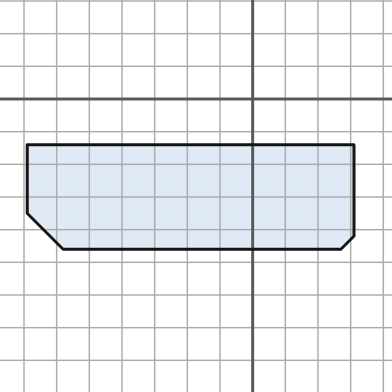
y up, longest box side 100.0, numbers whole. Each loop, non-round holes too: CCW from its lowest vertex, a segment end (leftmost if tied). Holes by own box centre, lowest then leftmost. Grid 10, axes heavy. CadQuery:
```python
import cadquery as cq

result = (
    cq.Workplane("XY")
    .moveTo(-58.0, -46.0)
    .lineTo(27.0, -46.0)
    .lineTo(31.0, -42.0)
    .lineTo(31.0, -14.0)
    .lineTo(-69.0, -14.0)
    .lineTo(-69.0, -35.0)
    .close()
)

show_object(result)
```